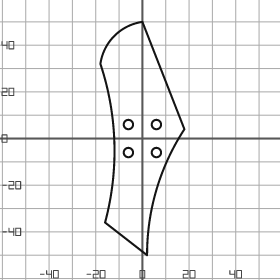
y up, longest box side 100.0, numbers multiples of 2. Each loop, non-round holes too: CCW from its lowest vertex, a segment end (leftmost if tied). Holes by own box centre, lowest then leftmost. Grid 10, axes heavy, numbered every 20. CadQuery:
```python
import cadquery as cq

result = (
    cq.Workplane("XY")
    .moveTo(2.0, -50.0)
    .threePointArc((6.0, -22.0), (18.0, 4.0))
    .lineTo(0.0, 50.0)
    .threePointArc((-12.0, 44.0), (-18.0, 32.0))
    .threePointArc((-12.0, -2.0), (-16.0, -36.0))
    .close()
    .moveTo(-6.0, -6.0)
    .circle(2.0)
    .moveTo(6.0, -6.0)
    .circle(2.0)
    .moveTo(-6.0, 6.0)
    .circle(2.0)
    .moveTo(6.0, 6.0)
    .circle(2.0)
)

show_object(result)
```